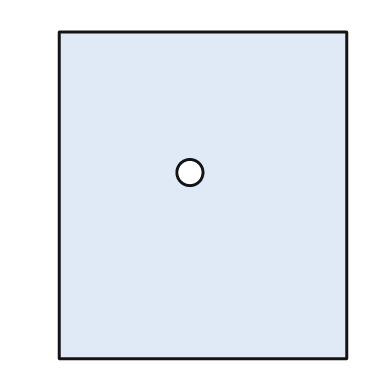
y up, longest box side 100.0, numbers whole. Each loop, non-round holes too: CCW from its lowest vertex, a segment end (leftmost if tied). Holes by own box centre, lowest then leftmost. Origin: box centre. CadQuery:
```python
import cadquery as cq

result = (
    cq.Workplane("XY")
    .moveTo(-44.0, -50.0)
    .lineTo(44.0, -50.0)
    .lineTo(44.0, 50.0)
    .lineTo(-44.0, 50.0)
    .close()
    .moveTo(-4.0, 7.0)
    .circle(4.0)
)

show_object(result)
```